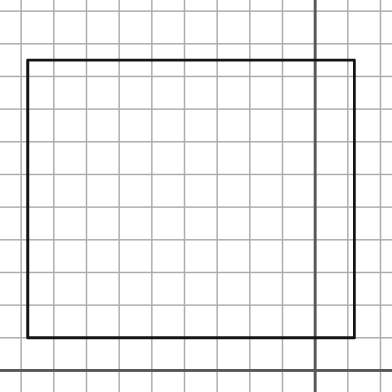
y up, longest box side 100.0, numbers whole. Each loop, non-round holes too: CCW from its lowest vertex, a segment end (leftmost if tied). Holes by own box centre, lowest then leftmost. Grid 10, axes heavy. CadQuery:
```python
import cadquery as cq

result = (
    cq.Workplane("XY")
    .moveTo(-88.0, 10.0)
    .lineTo(12.0, 10.0)
    .lineTo(12.0, 95.0)
    .lineTo(-88.0, 95.0)
    .close()
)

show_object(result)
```